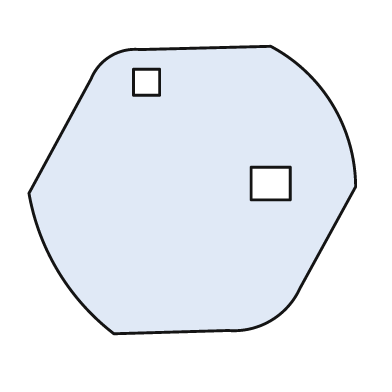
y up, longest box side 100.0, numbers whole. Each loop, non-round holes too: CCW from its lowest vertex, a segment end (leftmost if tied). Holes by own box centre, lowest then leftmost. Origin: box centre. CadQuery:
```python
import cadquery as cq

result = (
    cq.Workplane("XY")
    .moveTo(-24.0, -44.0)
    .lineTo(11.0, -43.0)
    .threePointArc((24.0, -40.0), (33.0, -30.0))
    .lineTo(50.0, 1.0)
    .threePointArc((43.0, 26.0), (24.0, 44.0))
    .lineTo(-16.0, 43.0)
    .threePointArc((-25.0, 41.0), (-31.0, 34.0))
    .lineTo(-50.0, -1.0)
    .threePointArc((-41.0, -25.0), (-24.0, -44.0))
    .close()
    .moveTo(18.0, -3.0)
    .lineTo(30.0, -3.0)
    .lineTo(30.0, 7.0)
    .lineTo(18.0, 7.0)
    .close()
    .moveTo(-18.0, 29.0)
    .lineTo(-10.0, 29.0)
    .lineTo(-10.0, 37.0)
    .lineTo(-18.0, 37.0)
    .close()
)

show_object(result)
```